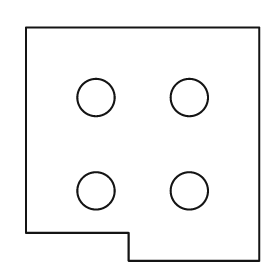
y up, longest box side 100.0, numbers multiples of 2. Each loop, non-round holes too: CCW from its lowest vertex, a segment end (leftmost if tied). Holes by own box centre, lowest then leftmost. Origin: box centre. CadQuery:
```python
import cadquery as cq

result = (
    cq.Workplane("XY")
    .moveTo(-6.0, -50.0)
    .lineTo(50.0, -50.0)
    .lineTo(50.0, 50.0)
    .lineTo(-50.0, 50.0)
    .lineTo(-50.0, -38.0)
    .lineTo(-6.0, -38.0)
    .close()
    .moveTo(-20.0, -20.0)
    .circle(8.0)
    .moveTo(20.0, -20.0)
    .circle(8.0)
    .moveTo(-20.0, 20.0)
    .circle(8.0)
    .moveTo(20.0, 20.0)
    .circle(8.0)
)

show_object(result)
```